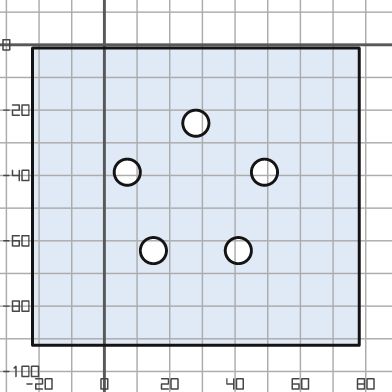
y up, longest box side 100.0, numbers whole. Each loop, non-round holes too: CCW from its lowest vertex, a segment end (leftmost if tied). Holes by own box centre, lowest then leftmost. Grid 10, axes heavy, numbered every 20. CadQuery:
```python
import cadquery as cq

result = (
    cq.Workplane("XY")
    .moveTo(-22.0, -92.0)
    .lineTo(78.0, -92.0)
    .lineTo(78.0, -1.0)
    .lineTo(-22.0, -1.0)
    .close()
    .moveTo(15.0, -63.0)
    .circle(4.0)
    .moveTo(41.0, -63.0)
    .circle(4.0)
    .moveTo(7.0, -39.0)
    .circle(4.0)
    .moveTo(49.0, -39.0)
    .circle(4.0)
    .moveTo(28.0, -24.0)
    .circle(4.0)
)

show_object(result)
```